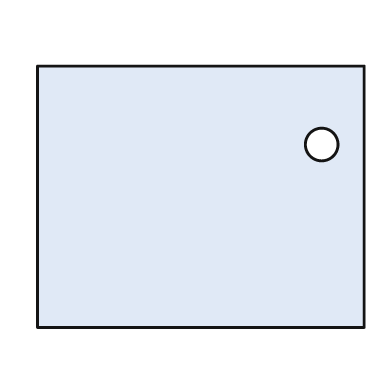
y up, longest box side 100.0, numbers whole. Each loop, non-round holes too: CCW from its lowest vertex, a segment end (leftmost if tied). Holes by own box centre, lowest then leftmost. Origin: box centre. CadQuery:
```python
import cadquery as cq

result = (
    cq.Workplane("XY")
    .moveTo(-50.0, -40.0)
    .lineTo(50.0, -40.0)
    .lineTo(50.0, 40.0)
    .lineTo(-50.0, 40.0)
    .close()
    .moveTo(37.0, 16.0)
    .circle(5.0)
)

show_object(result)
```